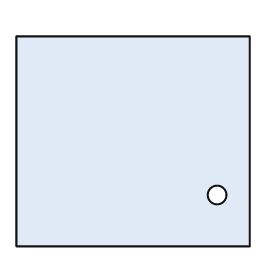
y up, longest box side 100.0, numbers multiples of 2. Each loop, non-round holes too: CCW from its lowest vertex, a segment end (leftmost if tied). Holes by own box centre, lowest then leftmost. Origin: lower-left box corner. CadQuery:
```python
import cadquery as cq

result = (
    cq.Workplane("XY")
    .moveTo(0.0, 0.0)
    .lineTo(100.0, 0.0)
    .lineTo(100.0, 90.0)
    .lineTo(0.0, 90.0)
    .close()
    .moveTo(86.0, 22.0)
    .circle(4.0)
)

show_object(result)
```